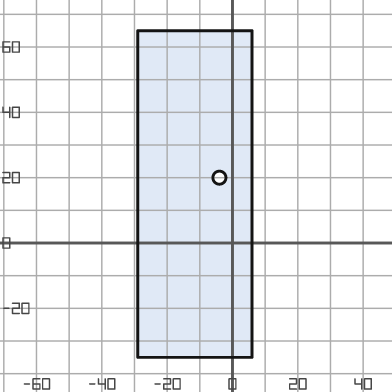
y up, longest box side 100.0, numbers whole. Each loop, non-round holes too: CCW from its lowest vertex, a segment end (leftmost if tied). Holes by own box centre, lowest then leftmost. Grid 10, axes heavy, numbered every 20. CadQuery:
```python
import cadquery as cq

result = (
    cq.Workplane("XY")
    .moveTo(-29.0, -35.0)
    .lineTo(6.0, -35.0)
    .lineTo(6.0, 65.0)
    .lineTo(-29.0, 65.0)
    .close()
    .moveTo(-4.0, 20.0)
    .circle(2.0)
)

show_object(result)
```